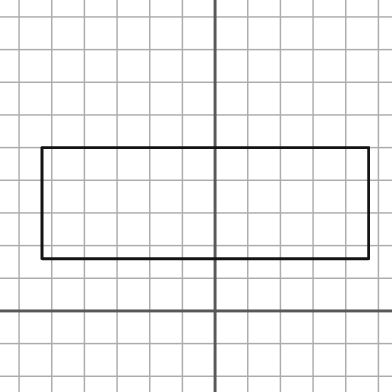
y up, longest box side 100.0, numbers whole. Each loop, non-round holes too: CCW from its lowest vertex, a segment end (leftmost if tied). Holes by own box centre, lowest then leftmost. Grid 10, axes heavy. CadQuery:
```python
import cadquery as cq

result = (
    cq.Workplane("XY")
    .moveTo(-53.0, 16.0)
    .lineTo(47.0, 16.0)
    .lineTo(47.0, 50.0)
    .lineTo(-53.0, 50.0)
    .close()
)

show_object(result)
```